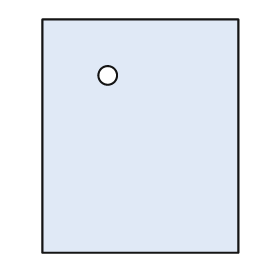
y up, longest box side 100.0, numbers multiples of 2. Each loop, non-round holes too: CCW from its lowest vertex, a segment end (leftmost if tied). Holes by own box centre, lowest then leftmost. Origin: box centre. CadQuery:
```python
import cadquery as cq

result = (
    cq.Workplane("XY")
    .moveTo(-42.0, -50.0)
    .lineTo(42.0, -50.0)
    .lineTo(42.0, 50.0)
    .lineTo(-42.0, 50.0)
    .close()
    .moveTo(-14.0, 26.0)
    .circle(4.0)
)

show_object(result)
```